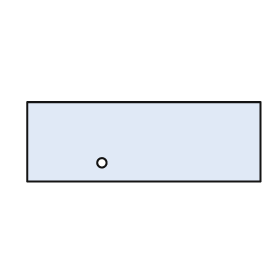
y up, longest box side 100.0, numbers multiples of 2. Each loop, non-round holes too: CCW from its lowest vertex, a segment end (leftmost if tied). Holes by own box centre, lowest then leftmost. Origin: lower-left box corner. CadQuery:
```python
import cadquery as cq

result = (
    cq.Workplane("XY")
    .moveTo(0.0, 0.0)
    .lineTo(100.0, 0.0)
    .lineTo(100.0, 34.0)
    .lineTo(0.0, 34.0)
    .close()
    .moveTo(32.0, 8.0)
    .circle(2.0)
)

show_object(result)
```